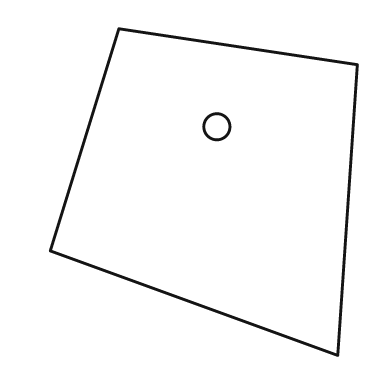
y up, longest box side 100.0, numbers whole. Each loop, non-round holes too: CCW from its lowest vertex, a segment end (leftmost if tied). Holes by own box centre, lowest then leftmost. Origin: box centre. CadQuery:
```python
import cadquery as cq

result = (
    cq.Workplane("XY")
    .moveTo(41.0, -50.0)
    .lineTo(47.0, 39.0)
    .lineTo(-26.0, 50.0)
    .lineTo(-47.0, -18.0)
    .close()
    .moveTo(4.0, 20.0)
    .circle(4.0)
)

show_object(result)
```